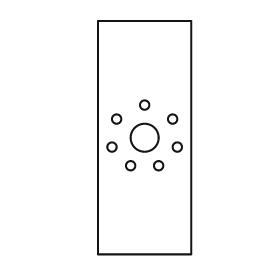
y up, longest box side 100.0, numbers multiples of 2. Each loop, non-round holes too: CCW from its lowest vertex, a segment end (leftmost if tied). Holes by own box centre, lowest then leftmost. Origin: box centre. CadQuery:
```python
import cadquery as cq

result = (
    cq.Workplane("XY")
    .moveTo(-20.0, -50.0)
    .lineTo(20.0, -50.0)
    .lineTo(20.0, 50.0)
    .lineTo(-20.0, 50.0)
    .close()
    .moveTo(-6.0, -12.0)
    .circle(2.0)
    .moveTo(6.0, -12.0)
    .circle(2.0)
    .moveTo(-14.0, -4.0)
    .circle(2.0)
    .moveTo(14.0, -4.0)
    .circle(2.0)
    .moveTo(0.0, 0.0)
    .circle(6.0)
    .moveTo(-12.0, 8.0)
    .circle(2.0)
    .moveTo(12.0, 8.0)
    .circle(2.0)
    .moveTo(0.0, 14.0)
    .circle(2.0)
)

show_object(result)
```